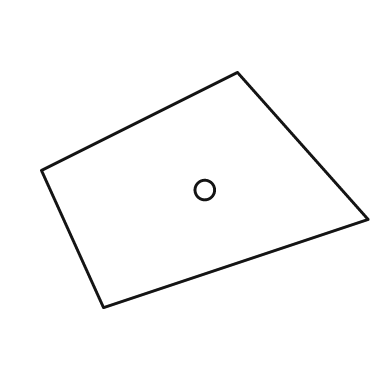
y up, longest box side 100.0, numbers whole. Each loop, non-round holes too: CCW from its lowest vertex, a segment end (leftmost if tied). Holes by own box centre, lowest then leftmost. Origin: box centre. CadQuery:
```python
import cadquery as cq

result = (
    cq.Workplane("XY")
    .moveTo(-31.0, -36.0)
    .lineTo(50.0, -9.0)
    .lineTo(10.0, 36.0)
    .lineTo(-50.0, 6.0)
    .close()
    .moveTo(0.0, 0.0)
    .circle(3.0)
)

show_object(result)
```